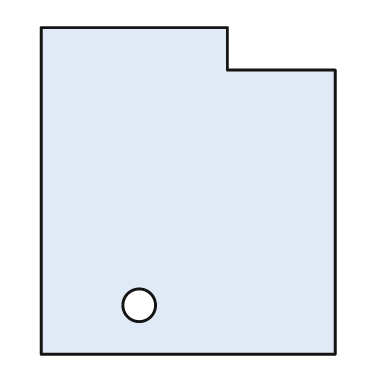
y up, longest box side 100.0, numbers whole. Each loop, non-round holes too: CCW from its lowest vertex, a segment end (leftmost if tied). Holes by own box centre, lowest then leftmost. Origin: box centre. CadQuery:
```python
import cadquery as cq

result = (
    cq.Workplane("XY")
    .moveTo(-45.0, -50.0)
    .lineTo(45.0, -50.0)
    .lineTo(45.0, 37.0)
    .lineTo(12.0, 37.0)
    .lineTo(12.0, 50.0)
    .lineTo(-45.0, 50.0)
    .close()
    .moveTo(-15.0, -35.0)
    .circle(5.0)
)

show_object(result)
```